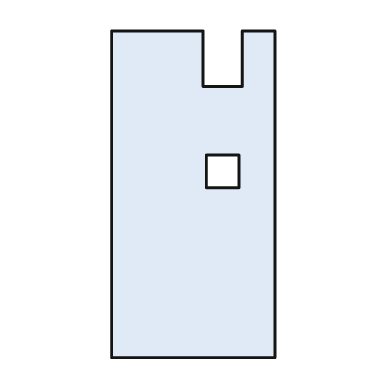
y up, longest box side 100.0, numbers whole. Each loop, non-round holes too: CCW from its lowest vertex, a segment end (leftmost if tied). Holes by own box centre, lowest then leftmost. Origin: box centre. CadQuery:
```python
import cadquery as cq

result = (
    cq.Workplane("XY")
    .moveTo(-25.0, -50.0)
    .lineTo(25.0, -50.0)
    .lineTo(25.0, 50.0)
    .lineTo(15.0, 50.0)
    .lineTo(15.0, 33.0)
    .lineTo(3.0, 33.0)
    .lineTo(3.0, 50.0)
    .lineTo(-25.0, 50.0)
    .close()
    .moveTo(4.0, 2.0)
    .lineTo(14.0, 2.0)
    .lineTo(14.0, 12.0)
    .lineTo(4.0, 12.0)
    .close()
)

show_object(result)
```